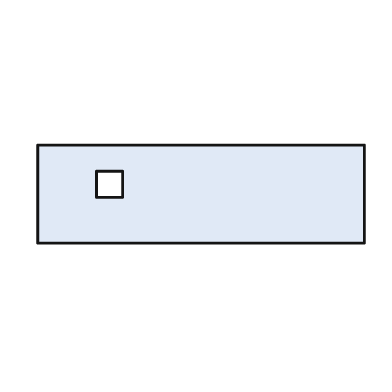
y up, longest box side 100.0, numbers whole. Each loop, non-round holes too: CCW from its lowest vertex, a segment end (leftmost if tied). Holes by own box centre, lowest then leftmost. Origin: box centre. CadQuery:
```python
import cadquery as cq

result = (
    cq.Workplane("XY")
    .moveTo(-50.0, -15.0)
    .lineTo(50.0, -15.0)
    .lineTo(50.0, 15.0)
    .lineTo(-50.0, 15.0)
    .close()
    .moveTo(-32.0, -1.0)
    .lineTo(-24.0, -1.0)
    .lineTo(-24.0, 7.0)
    .lineTo(-32.0, 7.0)
    .close()
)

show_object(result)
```